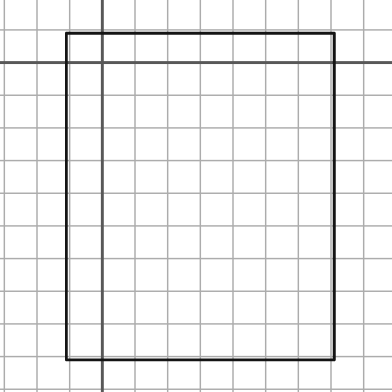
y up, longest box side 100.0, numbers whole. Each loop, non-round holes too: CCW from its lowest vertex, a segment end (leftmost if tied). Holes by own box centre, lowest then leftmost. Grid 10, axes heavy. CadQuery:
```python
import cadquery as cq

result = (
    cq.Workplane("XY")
    .moveTo(-11.0, -91.0)
    .lineTo(71.0, -91.0)
    .lineTo(71.0, 9.0)
    .lineTo(-11.0, 9.0)
    .close()
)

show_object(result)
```